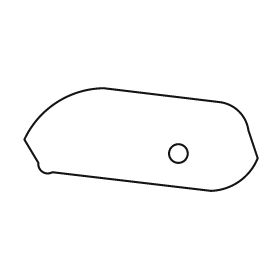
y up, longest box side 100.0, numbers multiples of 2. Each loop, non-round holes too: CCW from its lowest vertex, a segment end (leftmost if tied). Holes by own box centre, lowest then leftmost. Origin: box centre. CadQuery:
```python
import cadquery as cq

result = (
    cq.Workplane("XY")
    .moveTo(30.0, -22.0)
    .threePointArc((42.0, -18.0), (50.0, -8.0))
    .lineTo(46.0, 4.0)
    .threePointArc((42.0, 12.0), (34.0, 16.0))
    .lineTo(-16.0, 22.0)
    .threePointArc((-36.0, 16.0), (-50.0, 0.0))
    .lineTo(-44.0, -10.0)
    .threePointArc((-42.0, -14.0), (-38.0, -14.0))
    .close()
    .moveTo(16.0, -6.0)
    .circle(4.0)
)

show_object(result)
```